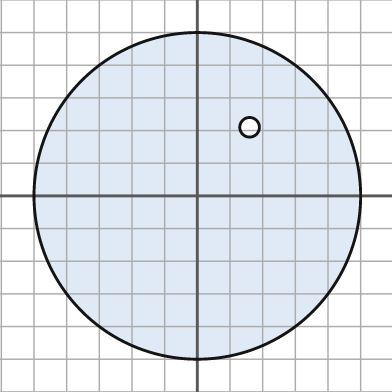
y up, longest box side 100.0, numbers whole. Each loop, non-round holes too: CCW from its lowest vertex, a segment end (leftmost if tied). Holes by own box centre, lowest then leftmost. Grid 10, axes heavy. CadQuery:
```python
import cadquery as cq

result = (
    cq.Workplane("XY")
    .moveTo(0.0, 0.0)
    .circle(50.0)
    .moveTo(16.0, 21.0)
    .circle(3.0)
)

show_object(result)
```